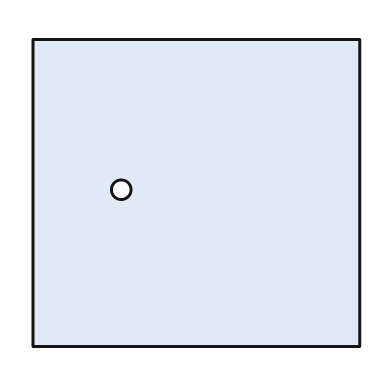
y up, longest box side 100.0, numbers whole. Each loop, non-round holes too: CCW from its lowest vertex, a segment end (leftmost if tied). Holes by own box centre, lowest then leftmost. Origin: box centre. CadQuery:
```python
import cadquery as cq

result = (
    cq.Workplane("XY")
    .moveTo(-50.0, -47.0)
    .lineTo(50.0, -47.0)
    .lineTo(50.0, 47.0)
    .lineTo(-50.0, 47.0)
    .close()
    .moveTo(-23.0, 1.0)
    .circle(3.0)
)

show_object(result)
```